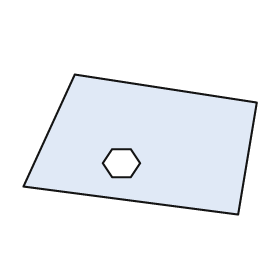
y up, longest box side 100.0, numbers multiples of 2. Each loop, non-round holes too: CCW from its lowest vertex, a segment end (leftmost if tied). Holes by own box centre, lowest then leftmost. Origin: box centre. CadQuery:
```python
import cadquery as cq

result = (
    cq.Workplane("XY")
    .moveTo(42.0, -30.0)
    .lineTo(50.0, 18.0)
    .lineTo(-28.0, 30.0)
    .lineTo(-50.0, -18.0)
    .close()
    .moveTo(-12.0, -14.0)
    .lineTo(-4.0, -14.0)
    .lineTo(0.0, -8.0)
    .lineTo(-4.0, -2.0)
    .lineTo(-12.0, -2.0)
    .lineTo(-16.0, -8.0)
    .close()
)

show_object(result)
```